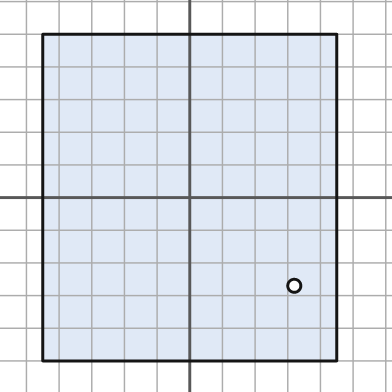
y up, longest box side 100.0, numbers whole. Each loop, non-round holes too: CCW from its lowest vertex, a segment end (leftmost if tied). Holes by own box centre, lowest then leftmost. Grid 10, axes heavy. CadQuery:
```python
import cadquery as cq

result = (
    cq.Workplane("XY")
    .moveTo(-45.0, -50.0)
    .lineTo(45.0, -50.0)
    .lineTo(45.0, 50.0)
    .lineTo(-45.0, 50.0)
    .close()
    .moveTo(32.0, -27.0)
    .circle(2.0)
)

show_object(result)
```